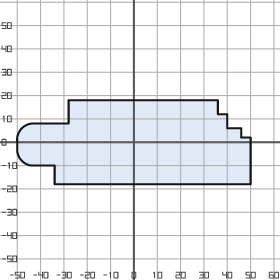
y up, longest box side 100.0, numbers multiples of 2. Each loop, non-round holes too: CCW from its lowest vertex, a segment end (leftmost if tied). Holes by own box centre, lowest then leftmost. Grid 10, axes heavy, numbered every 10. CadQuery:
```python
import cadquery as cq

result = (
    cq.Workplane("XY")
    .moveTo(-34.0, -18.0)
    .lineTo(50.0, -18.0)
    .lineTo(50.0, 2.0)
    .lineTo(46.0, 2.0)
    .lineTo(46.0, 6.0)
    .lineTo(40.0, 6.0)
    .lineTo(40.0, 12.0)
    .lineTo(36.0, 12.0)
    .lineTo(36.0, 18.0)
    .lineTo(-28.0, 18.0)
    .lineTo(-28.0, 8.0)
    .lineTo(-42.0, 8.0)
    .threePointArc((-48.0, 6.0), (-50.0, 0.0))
    .lineTo(-50.0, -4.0)
    .threePointArc((-48.0, -8.0), (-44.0, -10.0))
    .lineTo(-34.0, -10.0)
    .close()
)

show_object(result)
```